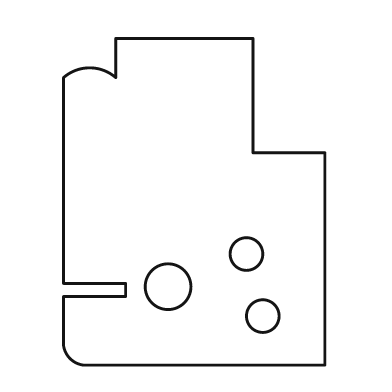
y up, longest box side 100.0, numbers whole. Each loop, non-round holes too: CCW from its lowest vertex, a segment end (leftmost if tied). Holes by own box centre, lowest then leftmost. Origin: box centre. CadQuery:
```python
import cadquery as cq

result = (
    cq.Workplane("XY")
    .moveTo(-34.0, -50.0)
    .lineTo(40.0, -50.0)
    .lineTo(40.0, 15.0)
    .lineTo(18.0, 15.0)
    .lineTo(18.0, 50.0)
    .lineTo(-24.0, 50.0)
    .lineTo(-24.0, 38.0)
    .threePointArc((-32.0, 41.0), (-40.0, 38.0))
    .lineTo(-40.0, -25.0)
    .lineTo(-21.0, -25.0)
    .lineTo(-21.0, -29.0)
    .lineTo(-40.0, -29.0)
    .lineTo(-40.0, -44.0)
    .threePointArc((-38.0, -48.0), (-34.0, -50.0))
    .close()
    .moveTo(21.0, -35.0)
    .circle(5.0)
    .moveTo(-8.0, -26.0)
    .circle(7.0)
    .moveTo(16.0, -16.0)
    .circle(5.0)
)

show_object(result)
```